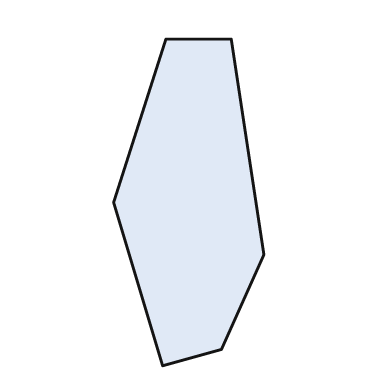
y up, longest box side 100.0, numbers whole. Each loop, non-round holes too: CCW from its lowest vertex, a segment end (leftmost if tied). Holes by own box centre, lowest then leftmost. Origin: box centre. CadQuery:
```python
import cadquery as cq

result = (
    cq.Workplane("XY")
    .moveTo(-8.0, -50.0)
    .lineTo(10.0, -45.0)
    .lineTo(23.0, -16.0)
    .lineTo(13.0, 50.0)
    .lineTo(-7.0, 50.0)
    .lineTo(-23.0, 0.0)
    .close()
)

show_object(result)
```